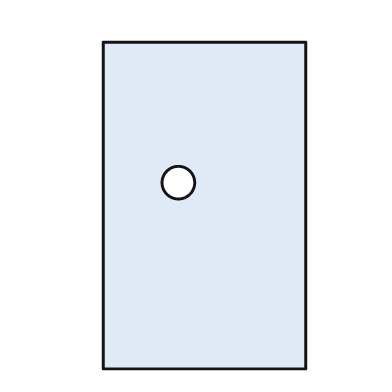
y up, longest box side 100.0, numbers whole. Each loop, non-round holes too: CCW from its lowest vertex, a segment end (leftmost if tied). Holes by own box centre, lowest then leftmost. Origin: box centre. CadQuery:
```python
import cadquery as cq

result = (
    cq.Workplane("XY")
    .moveTo(-31.0, -50.0)
    .lineTo(31.0, -50.0)
    .lineTo(31.0, 50.0)
    .lineTo(-31.0, 50.0)
    .close()
    .moveTo(-8.0, 7.0)
    .circle(5.0)
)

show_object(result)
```